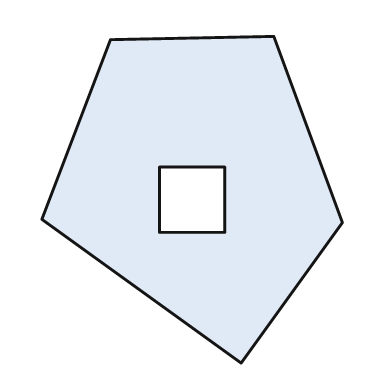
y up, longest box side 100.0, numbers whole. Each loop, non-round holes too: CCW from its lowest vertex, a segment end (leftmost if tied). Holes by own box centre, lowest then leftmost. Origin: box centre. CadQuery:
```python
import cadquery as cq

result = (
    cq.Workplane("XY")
    .moveTo(15.0, -50.0)
    .lineTo(46.0, -7.0)
    .lineTo(25.0, 50.0)
    .lineTo(-25.0, 49.0)
    .lineTo(-46.0, -6.0)
    .close()
    .moveTo(-10.0, -10.0)
    .lineTo(10.0, -10.0)
    .lineTo(10.0, 10.0)
    .lineTo(-10.0, 10.0)
    .close()
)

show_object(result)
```